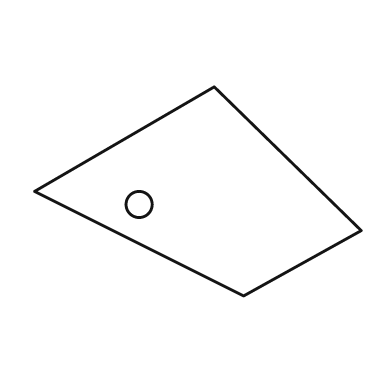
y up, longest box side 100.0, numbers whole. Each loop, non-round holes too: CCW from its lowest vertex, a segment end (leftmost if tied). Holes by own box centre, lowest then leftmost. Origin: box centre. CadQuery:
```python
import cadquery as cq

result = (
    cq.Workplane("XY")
    .moveTo(14.0, -32.0)
    .lineTo(50.0, -12.0)
    .lineTo(5.0, 32.0)
    .lineTo(-50.0, 0.0)
    .close()
    .moveTo(-18.0, -4.0)
    .circle(4.0)
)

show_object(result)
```